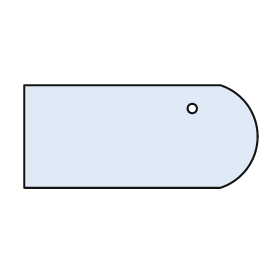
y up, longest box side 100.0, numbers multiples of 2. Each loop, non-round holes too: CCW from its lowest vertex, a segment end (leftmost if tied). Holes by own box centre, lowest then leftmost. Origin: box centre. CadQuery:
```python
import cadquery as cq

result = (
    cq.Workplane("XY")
    .moveTo(-50.0, -22.0)
    .lineTo(34.0, -22.0)
    .threePointArc((50.0, 0.0), (34.0, 22.0))
    .lineTo(-50.0, 22.0)
    .close()
    .moveTo(22.0, 12.0)
    .circle(2.0)
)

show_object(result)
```